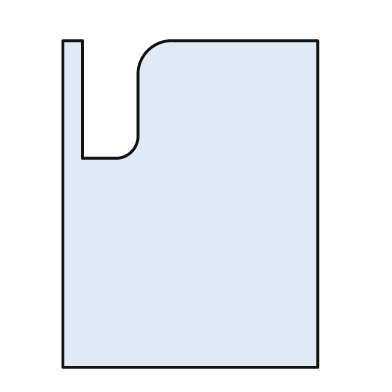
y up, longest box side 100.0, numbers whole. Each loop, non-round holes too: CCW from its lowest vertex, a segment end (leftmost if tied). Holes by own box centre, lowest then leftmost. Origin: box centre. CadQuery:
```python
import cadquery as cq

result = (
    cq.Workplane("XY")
    .moveTo(-39.0, -50.0)
    .lineTo(39.0, -50.0)
    .lineTo(39.0, 50.0)
    .lineTo(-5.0, 50.0)
    .threePointArc((-13.0, 47.0), (-16.0, 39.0))
    .lineTo(-16.0, 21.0)
    .threePointArc((-18.0, 16.0), (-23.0, 14.0))
    .lineTo(-33.0, 14.0)
    .lineTo(-33.0, 50.0)
    .lineTo(-39.0, 50.0)
    .close()
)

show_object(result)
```